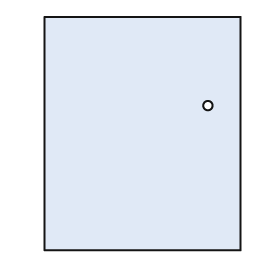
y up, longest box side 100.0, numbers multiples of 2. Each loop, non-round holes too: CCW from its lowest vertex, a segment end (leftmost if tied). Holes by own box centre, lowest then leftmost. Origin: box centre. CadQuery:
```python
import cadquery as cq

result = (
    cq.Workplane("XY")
    .moveTo(-42.0, -50.0)
    .lineTo(42.0, -50.0)
    .lineTo(42.0, 50.0)
    .lineTo(-42.0, 50.0)
    .close()
    .moveTo(28.0, 12.0)
    .circle(2.0)
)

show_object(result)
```